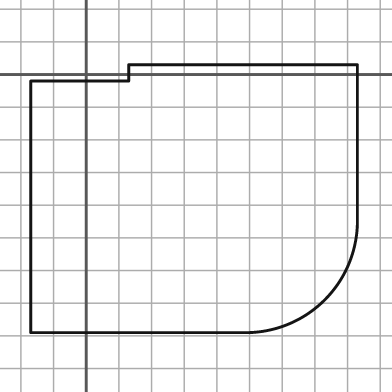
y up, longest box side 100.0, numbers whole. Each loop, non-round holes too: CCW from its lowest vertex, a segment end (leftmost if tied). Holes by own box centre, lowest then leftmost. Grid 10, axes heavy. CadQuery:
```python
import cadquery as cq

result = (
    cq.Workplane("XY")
    .moveTo(-17.0, -79.0)
    .lineTo(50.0, -79.0)
    .threePointArc((73.0, -69.0), (83.0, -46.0))
    .lineTo(83.0, 3.0)
    .lineTo(13.0, 3.0)
    .lineTo(13.0, -2.0)
    .lineTo(-17.0, -2.0)
    .close()
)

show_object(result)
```